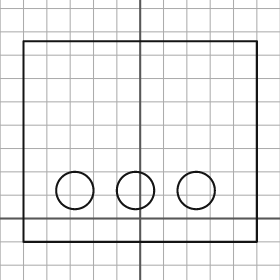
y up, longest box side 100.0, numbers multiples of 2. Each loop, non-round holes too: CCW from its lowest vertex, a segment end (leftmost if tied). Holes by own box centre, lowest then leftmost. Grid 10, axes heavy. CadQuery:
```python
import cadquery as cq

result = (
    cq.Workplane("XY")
    .moveTo(-50.0, -10.0)
    .lineTo(50.0, -10.0)
    .lineTo(50.0, 76.0)
    .lineTo(-50.0, 76.0)
    .close()
    .moveTo(-28.0, 12.0)
    .circle(8.0)
    .moveTo(-2.0, 12.0)
    .circle(8.0)
    .moveTo(24.0, 12.0)
    .circle(8.0)
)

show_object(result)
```